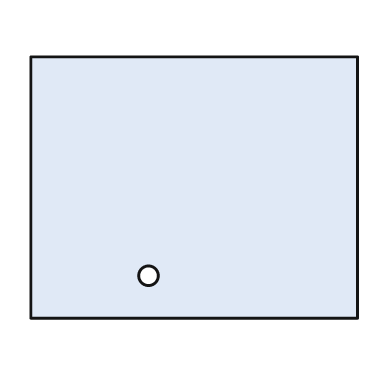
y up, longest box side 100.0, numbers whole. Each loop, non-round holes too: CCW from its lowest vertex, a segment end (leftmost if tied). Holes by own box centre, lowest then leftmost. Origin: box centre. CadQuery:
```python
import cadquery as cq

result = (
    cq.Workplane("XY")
    .moveTo(-50.0, -40.0)
    .lineTo(50.0, -40.0)
    .lineTo(50.0, 40.0)
    .lineTo(-50.0, 40.0)
    .close()
    .moveTo(-14.0, -27.0)
    .circle(3.0)
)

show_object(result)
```